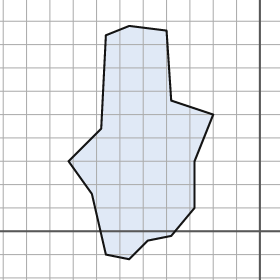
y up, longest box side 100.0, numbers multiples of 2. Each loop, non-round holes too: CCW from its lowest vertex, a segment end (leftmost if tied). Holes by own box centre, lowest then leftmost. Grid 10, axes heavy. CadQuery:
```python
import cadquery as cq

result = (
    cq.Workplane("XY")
    .moveTo(-56.0, -12.0)
    .lineTo(-48.0, -4.0)
    .lineTo(-38.0, -2.0)
    .lineTo(-28.0, 10.0)
    .lineTo(-28.0, 30.0)
    .lineTo(-20.0, 50.0)
    .lineTo(-38.0, 56.0)
    .lineTo(-40.0, 86.0)
    .lineTo(-56.0, 88.0)
    .lineTo(-66.0, 84.0)
    .lineTo(-68.0, 44.0)
    .lineTo(-82.0, 30.0)
    .lineTo(-72.0, 16.0)
    .lineTo(-66.0, -10.0)
    .close()
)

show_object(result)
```